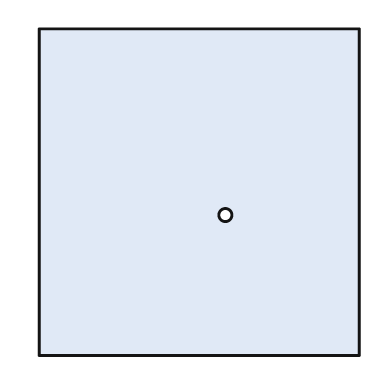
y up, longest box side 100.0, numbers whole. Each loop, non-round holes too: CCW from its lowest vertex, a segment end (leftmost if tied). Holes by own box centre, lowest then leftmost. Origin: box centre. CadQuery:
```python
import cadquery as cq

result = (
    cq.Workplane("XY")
    .moveTo(-49.0, -50.0)
    .lineTo(49.0, -50.0)
    .lineTo(49.0, 50.0)
    .lineTo(-49.0, 50.0)
    .close()
    .moveTo(8.0, -7.0)
    .circle(2.0)
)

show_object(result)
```